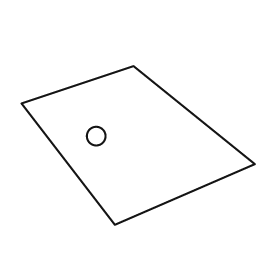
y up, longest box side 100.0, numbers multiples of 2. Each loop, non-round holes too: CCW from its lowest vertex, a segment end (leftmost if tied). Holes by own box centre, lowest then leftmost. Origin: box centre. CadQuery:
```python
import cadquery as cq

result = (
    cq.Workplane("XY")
    .moveTo(-10.0, -34.0)
    .lineTo(50.0, -8.0)
    .lineTo(-2.0, 34.0)
    .lineTo(-50.0, 18.0)
    .close()
    .moveTo(-18.0, 4.0)
    .circle(4.0)
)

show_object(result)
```